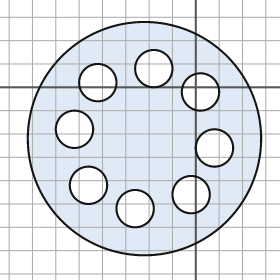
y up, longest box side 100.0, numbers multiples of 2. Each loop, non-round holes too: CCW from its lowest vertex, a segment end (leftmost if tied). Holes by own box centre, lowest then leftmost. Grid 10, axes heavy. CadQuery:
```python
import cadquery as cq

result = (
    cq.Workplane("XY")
    .moveTo(-22.0, -22.0)
    .circle(50.0)
    .moveTo(-26.0, -52.0)
    .circle(8.0)
    .moveTo(-2.0, -46.0)
    .circle(8.0)
    .moveTo(-46.0, -42.0)
    .circle(8.0)
    .moveTo(8.0, -26.0)
    .circle(8.0)
    .moveTo(-52.0, -18.0)
    .circle(8.0)
    .moveTo(2.0, -2.0)
    .circle(8.0)
    .moveTo(-42.0, 2.0)
    .circle(8.0)
    .moveTo(-18.0, 8.0)
    .circle(8.0)
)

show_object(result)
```